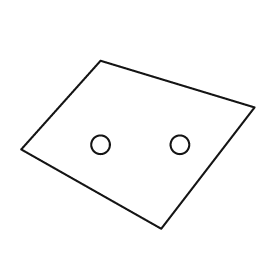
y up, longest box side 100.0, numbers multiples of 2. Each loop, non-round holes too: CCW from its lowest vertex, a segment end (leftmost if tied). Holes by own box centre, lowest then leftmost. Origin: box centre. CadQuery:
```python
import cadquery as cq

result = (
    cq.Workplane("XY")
    .moveTo(10.0, -36.0)
    .lineTo(50.0, 16.0)
    .lineTo(-16.0, 36.0)
    .lineTo(-50.0, -2.0)
    .close()
    .moveTo(-16.0, 0.0)
    .circle(4.0)
    .moveTo(18.0, 0.0)
    .circle(4.0)
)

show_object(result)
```